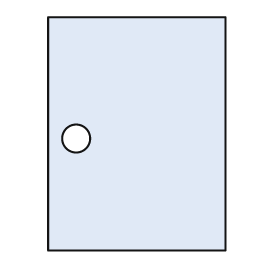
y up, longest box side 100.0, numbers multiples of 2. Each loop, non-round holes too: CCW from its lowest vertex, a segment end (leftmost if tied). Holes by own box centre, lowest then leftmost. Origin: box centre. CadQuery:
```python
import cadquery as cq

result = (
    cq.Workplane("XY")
    .moveTo(-38.0, -50.0)
    .lineTo(38.0, -50.0)
    .lineTo(38.0, 50.0)
    .lineTo(-38.0, 50.0)
    .close()
    .moveTo(-26.0, -2.0)
    .circle(6.0)
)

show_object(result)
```